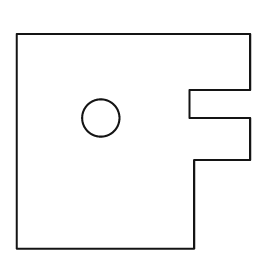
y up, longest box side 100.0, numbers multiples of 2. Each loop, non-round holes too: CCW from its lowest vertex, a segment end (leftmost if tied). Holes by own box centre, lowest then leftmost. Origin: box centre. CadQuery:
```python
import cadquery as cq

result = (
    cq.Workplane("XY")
    .moveTo(-50.0, -46.0)
    .lineTo(26.0, -46.0)
    .lineTo(26.0, -8.0)
    .lineTo(50.0, -8.0)
    .lineTo(50.0, 10.0)
    .lineTo(24.0, 10.0)
    .lineTo(24.0, 22.0)
    .lineTo(50.0, 22.0)
    .lineTo(50.0, 46.0)
    .lineTo(-50.0, 46.0)
    .close()
    .moveTo(-14.0, 10.0)
    .circle(8.0)
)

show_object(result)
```